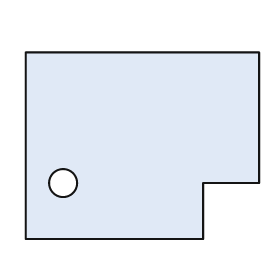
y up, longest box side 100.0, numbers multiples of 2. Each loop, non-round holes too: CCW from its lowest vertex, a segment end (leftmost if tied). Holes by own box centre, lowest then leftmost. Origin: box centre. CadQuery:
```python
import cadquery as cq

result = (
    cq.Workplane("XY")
    .moveTo(-50.0, -40.0)
    .lineTo(26.0, -40.0)
    .lineTo(26.0, -16.0)
    .lineTo(50.0, -16.0)
    .lineTo(50.0, 40.0)
    .lineTo(-50.0, 40.0)
    .close()
    .moveTo(-34.0, -16.0)
    .circle(6.0)
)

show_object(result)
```